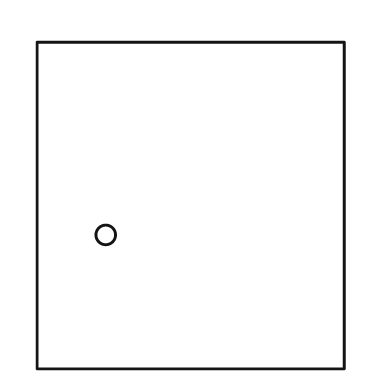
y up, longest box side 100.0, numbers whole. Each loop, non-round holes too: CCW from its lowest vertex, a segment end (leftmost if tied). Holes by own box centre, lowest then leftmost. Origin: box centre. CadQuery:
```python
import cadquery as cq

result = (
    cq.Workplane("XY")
    .moveTo(-47.0, -50.0)
    .lineTo(47.0, -50.0)
    .lineTo(47.0, 50.0)
    .lineTo(-47.0, 50.0)
    .close()
    .moveTo(-26.0, -9.0)
    .circle(3.0)
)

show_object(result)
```